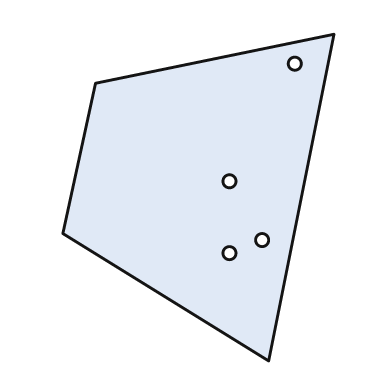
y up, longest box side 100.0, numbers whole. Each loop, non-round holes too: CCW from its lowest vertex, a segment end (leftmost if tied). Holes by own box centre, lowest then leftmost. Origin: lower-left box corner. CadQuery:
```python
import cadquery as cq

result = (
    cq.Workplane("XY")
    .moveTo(63.0, 0.0)
    .lineTo(83.0, 100.0)
    .lineTo(10.0, 85.0)
    .lineTo(0.0, 39.0)
    .close()
    .moveTo(51.0, 33.0)
    .circle(2.0)
    .moveTo(61.0, 37.0)
    .circle(2.0)
    .moveTo(51.0, 55.0)
    .circle(2.0)
    .moveTo(71.0, 91.0)
    .circle(2.0)
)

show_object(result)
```